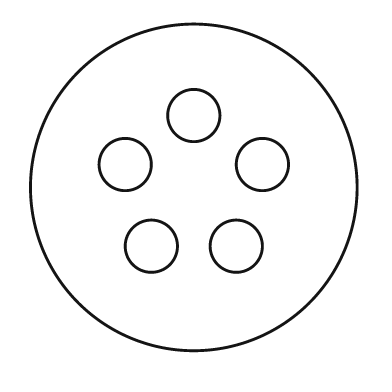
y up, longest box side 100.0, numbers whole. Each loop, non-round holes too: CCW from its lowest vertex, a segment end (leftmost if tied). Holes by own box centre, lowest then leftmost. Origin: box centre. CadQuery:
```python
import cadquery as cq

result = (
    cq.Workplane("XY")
    .moveTo(0.0, 0.0)
    .circle(50.0)
    .moveTo(-13.0, -18.0)
    .circle(8.0)
    .moveTo(13.0, -18.0)
    .circle(8.0)
    .moveTo(-21.0, 7.0)
    .circle(8.0)
    .moveTo(21.0, 7.0)
    .circle(8.0)
    .moveTo(0.0, 22.0)
    .circle(8.0)
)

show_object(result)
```